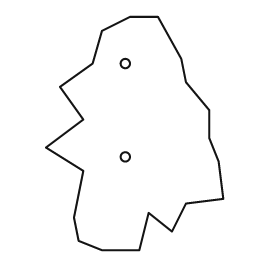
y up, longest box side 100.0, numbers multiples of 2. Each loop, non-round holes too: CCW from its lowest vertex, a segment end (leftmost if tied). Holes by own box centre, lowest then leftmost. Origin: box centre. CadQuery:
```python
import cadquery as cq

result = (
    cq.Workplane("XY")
    .moveTo(-14.0, -50.0)
    .lineTo(2.0, -50.0)
    .lineTo(6.0, -34.0)
    .lineTo(16.0, -42.0)
    .lineTo(22.0, -30.0)
    .lineTo(38.0, -28.0)
    .lineTo(36.0, -12.0)
    .lineTo(32.0, -2.0)
    .lineTo(32.0, 10.0)
    .lineTo(22.0, 22.0)
    .lineTo(20.0, 32.0)
    .lineTo(10.0, 50.0)
    .lineTo(-2.0, 50.0)
    .lineTo(-14.0, 44.0)
    .lineTo(-18.0, 30.0)
    .lineTo(-32.0, 20.0)
    .lineTo(-22.0, 6.0)
    .lineTo(-38.0, -6.0)
    .lineTo(-22.0, -16.0)
    .lineTo(-26.0, -36.0)
    .lineTo(-24.0, -46.0)
    .close()
    .moveTo(-4.0, -10.0)
    .circle(2.0)
    .moveTo(-4.0, 30.0)
    .circle(2.0)
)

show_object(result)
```